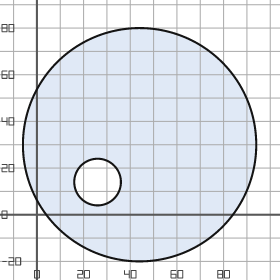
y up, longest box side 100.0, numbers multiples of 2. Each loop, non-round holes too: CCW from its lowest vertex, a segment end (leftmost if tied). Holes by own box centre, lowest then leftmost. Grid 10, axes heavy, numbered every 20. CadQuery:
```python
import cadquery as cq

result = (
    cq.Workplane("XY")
    .moveTo(44.0, 30.0)
    .circle(50.0)
    .moveTo(26.0, 14.0)
    .circle(10.0)
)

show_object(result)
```